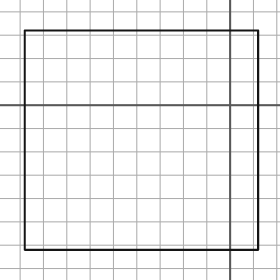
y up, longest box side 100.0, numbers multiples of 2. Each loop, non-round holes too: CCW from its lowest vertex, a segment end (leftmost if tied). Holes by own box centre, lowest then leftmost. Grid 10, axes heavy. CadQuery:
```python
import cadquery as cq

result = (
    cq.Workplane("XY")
    .moveTo(-88.0, -62.0)
    .lineTo(12.0, -62.0)
    .lineTo(12.0, 32.0)
    .lineTo(-88.0, 32.0)
    .close()
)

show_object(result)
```